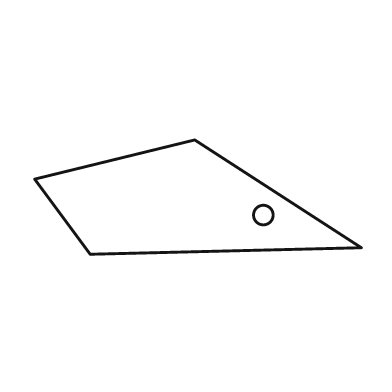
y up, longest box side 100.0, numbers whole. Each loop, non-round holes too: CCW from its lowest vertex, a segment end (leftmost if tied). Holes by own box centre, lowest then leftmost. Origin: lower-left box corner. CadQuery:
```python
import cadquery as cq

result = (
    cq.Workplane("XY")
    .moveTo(17.0, 0.0)
    .lineTo(100.0, 2.0)
    .lineTo(49.0, 35.0)
    .lineTo(0.0, 23.0)
    .close()
    .moveTo(70.0, 12.0)
    .circle(3.0)
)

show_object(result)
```